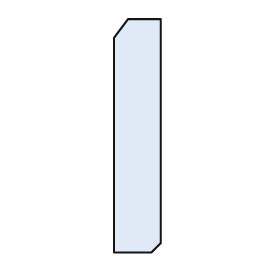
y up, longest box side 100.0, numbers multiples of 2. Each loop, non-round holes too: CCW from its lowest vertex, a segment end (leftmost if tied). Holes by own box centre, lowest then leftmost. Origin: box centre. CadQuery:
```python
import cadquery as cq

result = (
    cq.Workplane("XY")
    .moveTo(-10.0, -50.0)
    .lineTo(6.0, -50.0)
    .lineTo(10.0, -46.0)
    .lineTo(10.0, 50.0)
    .lineTo(-4.0, 50.0)
    .lineTo(-10.0, 42.0)
    .close()
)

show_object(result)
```